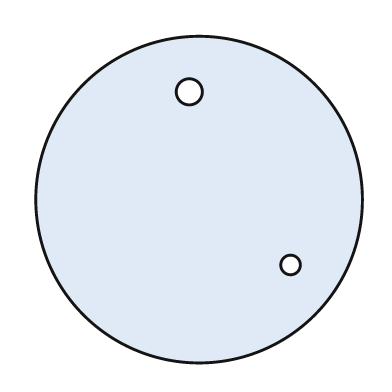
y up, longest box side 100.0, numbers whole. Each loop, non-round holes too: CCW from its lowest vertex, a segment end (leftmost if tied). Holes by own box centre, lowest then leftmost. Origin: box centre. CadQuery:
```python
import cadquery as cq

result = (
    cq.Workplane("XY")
    .moveTo(0.0, 0.0)
    .circle(50.0)
    .moveTo(28.0, -20.0)
    .circle(3.0)
    .moveTo(-3.0, 33.0)
    .circle(4.0)
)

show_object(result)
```